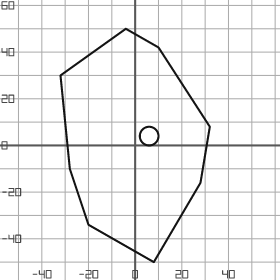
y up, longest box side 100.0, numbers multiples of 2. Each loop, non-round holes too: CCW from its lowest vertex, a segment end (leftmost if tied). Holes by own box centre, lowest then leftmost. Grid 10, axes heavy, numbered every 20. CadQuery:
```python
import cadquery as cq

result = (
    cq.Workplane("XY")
    .moveTo(8.0, -50.0)
    .lineTo(28.0, -16.0)
    .lineTo(32.0, 8.0)
    .lineTo(10.0, 42.0)
    .lineTo(-4.0, 50.0)
    .lineTo(-32.0, 30.0)
    .lineTo(-28.0, -10.0)
    .lineTo(-20.0, -34.0)
    .close()
    .moveTo(6.0, 4.0)
    .circle(4.0)
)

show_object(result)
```